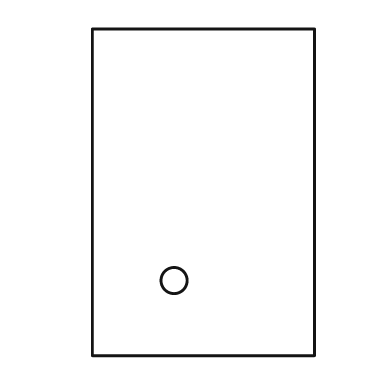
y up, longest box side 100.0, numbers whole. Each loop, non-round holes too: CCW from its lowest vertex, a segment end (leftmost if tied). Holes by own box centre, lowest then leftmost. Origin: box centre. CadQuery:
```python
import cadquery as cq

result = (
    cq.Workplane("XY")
    .moveTo(-34.0, -50.0)
    .lineTo(34.0, -50.0)
    .lineTo(34.0, 50.0)
    .lineTo(-34.0, 50.0)
    .close()
    .moveTo(-9.0, -27.0)
    .circle(4.0)
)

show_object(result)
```